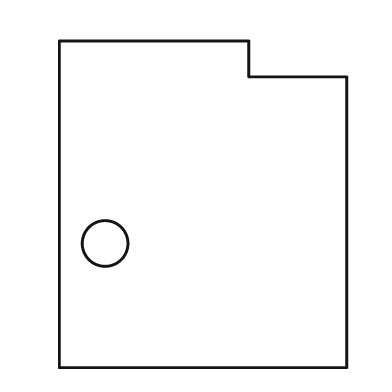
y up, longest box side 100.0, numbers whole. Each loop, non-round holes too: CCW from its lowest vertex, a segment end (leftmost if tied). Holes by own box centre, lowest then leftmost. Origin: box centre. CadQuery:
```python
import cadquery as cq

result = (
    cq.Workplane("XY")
    .moveTo(-44.0, -50.0)
    .lineTo(44.0, -50.0)
    .lineTo(44.0, 39.0)
    .lineTo(14.0, 39.0)
    .lineTo(14.0, 50.0)
    .lineTo(-44.0, 50.0)
    .close()
    .moveTo(-30.0, -12.0)
    .circle(7.0)
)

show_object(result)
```